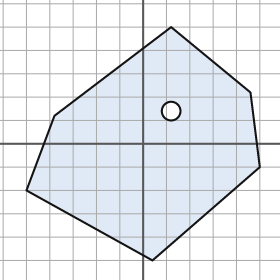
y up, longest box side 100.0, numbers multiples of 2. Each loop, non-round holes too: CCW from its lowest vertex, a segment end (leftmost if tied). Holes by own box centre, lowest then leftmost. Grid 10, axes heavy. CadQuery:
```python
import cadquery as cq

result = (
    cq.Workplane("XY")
    .moveTo(4.0, -50.0)
    .lineTo(50.0, -10.0)
    .lineTo(46.0, 22.0)
    .lineTo(12.0, 50.0)
    .lineTo(-38.0, 12.0)
    .lineTo(-50.0, -20.0)
    .close()
    .moveTo(12.0, 14.0)
    .circle(4.0)
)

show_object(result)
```